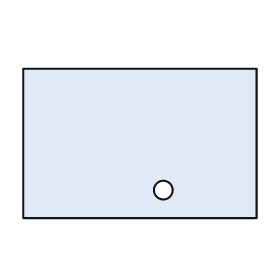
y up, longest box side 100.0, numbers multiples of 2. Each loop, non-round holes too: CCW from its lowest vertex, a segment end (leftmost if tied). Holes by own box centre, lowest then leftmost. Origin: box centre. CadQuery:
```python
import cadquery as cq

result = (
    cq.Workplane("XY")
    .moveTo(-50.0, -32.0)
    .lineTo(50.0, -32.0)
    .lineTo(50.0, 32.0)
    .lineTo(-50.0, 32.0)
    .close()
    .moveTo(10.0, -20.0)
    .circle(4.0)
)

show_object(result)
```